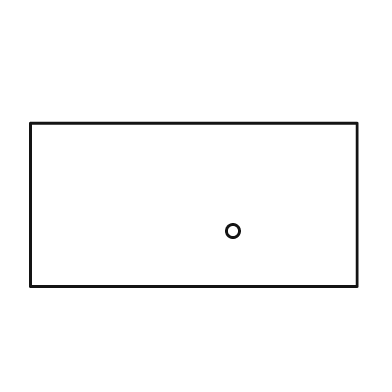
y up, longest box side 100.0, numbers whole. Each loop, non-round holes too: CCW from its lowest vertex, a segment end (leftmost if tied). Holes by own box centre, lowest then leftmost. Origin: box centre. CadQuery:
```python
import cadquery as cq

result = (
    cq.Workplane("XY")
    .moveTo(-50.0, -25.0)
    .lineTo(50.0, -25.0)
    .lineTo(50.0, 25.0)
    .lineTo(-50.0, 25.0)
    .close()
    .moveTo(12.0, -8.0)
    .circle(2.0)
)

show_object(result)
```